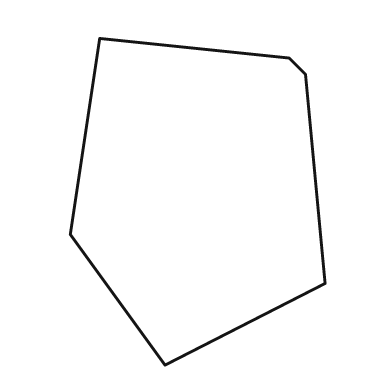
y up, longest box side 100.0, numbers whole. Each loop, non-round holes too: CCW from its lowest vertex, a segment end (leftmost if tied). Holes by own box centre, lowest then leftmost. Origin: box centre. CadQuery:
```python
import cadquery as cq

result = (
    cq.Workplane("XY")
    .moveTo(-10.0, -50.0)
    .lineTo(39.0, -25.0)
    .lineTo(33.0, 39.0)
    .lineTo(28.0, 44.0)
    .lineTo(-30.0, 50.0)
    .lineTo(-39.0, -10.0)
    .close()
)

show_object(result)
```